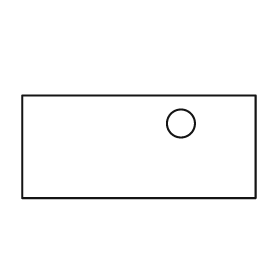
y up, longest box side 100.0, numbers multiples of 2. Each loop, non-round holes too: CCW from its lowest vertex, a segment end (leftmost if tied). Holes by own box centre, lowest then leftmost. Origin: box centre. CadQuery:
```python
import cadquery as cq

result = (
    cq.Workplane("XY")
    .moveTo(-50.0, -22.0)
    .lineTo(50.0, -22.0)
    .lineTo(50.0, 22.0)
    .lineTo(-50.0, 22.0)
    .close()
    .moveTo(18.0, 10.0)
    .circle(6.0)
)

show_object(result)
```